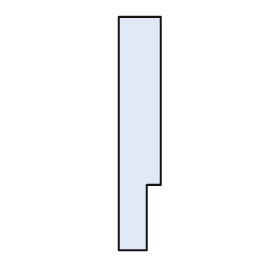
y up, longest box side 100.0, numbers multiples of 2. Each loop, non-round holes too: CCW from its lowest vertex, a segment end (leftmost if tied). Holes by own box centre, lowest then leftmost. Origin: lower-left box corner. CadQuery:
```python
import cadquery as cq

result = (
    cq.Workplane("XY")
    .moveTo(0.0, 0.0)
    .lineTo(12.0, 0.0)
    .lineTo(12.0, 28.0)
    .lineTo(18.0, 28.0)
    .lineTo(18.0, 100.0)
    .lineTo(0.0, 100.0)
    .close()
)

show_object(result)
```